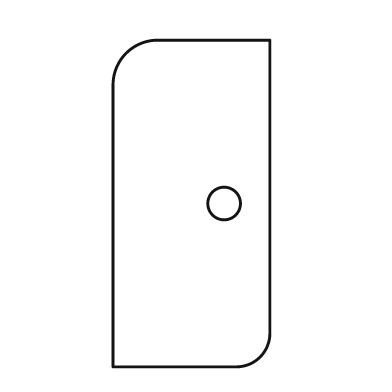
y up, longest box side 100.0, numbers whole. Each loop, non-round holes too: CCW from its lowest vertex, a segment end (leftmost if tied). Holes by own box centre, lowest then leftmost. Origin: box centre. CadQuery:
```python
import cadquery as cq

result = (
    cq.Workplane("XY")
    .moveTo(-24.0, -50.0)
    .lineTo(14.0, -50.0)
    .threePointArc((21.0, -47.0), (24.0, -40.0))
    .lineTo(24.0, 50.0)
    .lineTo(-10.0, 50.0)
    .threePointArc((-20.0, 46.0), (-24.0, 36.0))
    .close()
    .moveTo(10.0, 0.0)
    .circle(5.0)
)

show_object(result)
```